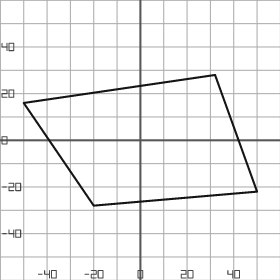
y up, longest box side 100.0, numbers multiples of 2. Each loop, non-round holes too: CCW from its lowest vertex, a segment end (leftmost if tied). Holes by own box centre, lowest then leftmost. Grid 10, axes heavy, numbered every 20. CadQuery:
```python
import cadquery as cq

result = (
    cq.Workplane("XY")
    .moveTo(-20.0, -28.0)
    .lineTo(50.0, -22.0)
    .lineTo(32.0, 28.0)
    .lineTo(-50.0, 16.0)
    .close()
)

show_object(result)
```